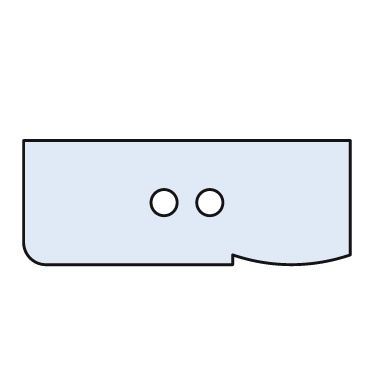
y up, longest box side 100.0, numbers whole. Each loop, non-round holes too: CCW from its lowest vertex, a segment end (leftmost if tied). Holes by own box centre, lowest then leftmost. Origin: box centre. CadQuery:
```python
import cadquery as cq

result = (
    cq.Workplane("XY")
    .moveTo(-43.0, -19.0)
    .lineTo(14.0, -19.0)
    .lineTo(14.0, -16.0)
    .threePointArc((32.0, -19.0), (50.0, -16.0))
    .lineTo(50.0, 19.0)
    .lineTo(-50.0, 19.0)
    .lineTo(-50.0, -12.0)
    .threePointArc((-48.0, -17.0), (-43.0, -19.0))
    .close()
    .moveTo(-7.0, 0.0)
    .circle(4.0)
    .moveTo(7.0, 0.0)
    .circle(4.0)
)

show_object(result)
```